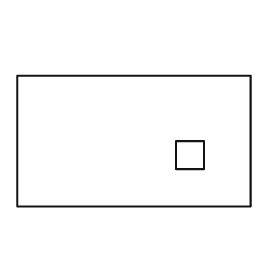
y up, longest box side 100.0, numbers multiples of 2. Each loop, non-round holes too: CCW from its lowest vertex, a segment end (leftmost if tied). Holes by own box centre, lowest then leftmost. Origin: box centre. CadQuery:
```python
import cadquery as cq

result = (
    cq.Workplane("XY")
    .moveTo(-50.0, -28.0)
    .lineTo(50.0, -28.0)
    .lineTo(50.0, 28.0)
    .lineTo(-50.0, 28.0)
    .close()
    .moveTo(18.0, -12.0)
    .lineTo(30.0, -12.0)
    .lineTo(30.0, 0.0)
    .lineTo(18.0, 0.0)
    .close()
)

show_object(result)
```